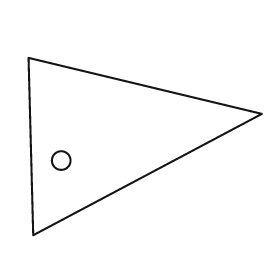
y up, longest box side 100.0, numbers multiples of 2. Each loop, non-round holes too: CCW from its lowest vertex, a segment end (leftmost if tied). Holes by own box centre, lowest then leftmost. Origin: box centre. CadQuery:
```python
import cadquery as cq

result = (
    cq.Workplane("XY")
    .moveTo(-48.0, -38.0)
    .lineTo(50.0, 14.0)
    .lineTo(-50.0, 38.0)
    .close()
    .moveTo(-36.0, -6.0)
    .circle(4.0)
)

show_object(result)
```